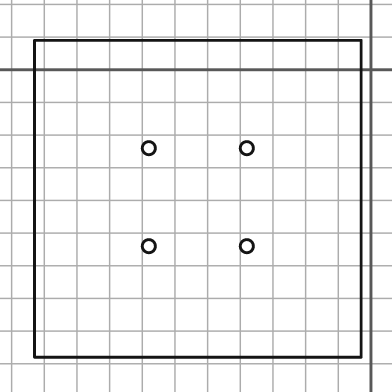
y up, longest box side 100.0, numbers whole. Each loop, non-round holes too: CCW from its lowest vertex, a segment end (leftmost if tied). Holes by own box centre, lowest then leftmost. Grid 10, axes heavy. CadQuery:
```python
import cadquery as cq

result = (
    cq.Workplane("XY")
    .moveTo(-103.0, -88.0)
    .lineTo(-3.0, -88.0)
    .lineTo(-3.0, 9.0)
    .lineTo(-103.0, 9.0)
    .close()
    .moveTo(-68.0, -54.0)
    .circle(2.0)
    .moveTo(-38.0, -54.0)
    .circle(2.0)
    .moveTo(-68.0, -24.0)
    .circle(2.0)
    .moveTo(-38.0, -24.0)
    .circle(2.0)
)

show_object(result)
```